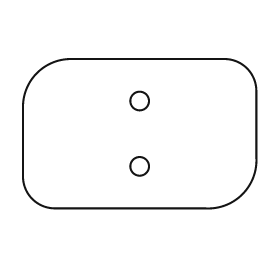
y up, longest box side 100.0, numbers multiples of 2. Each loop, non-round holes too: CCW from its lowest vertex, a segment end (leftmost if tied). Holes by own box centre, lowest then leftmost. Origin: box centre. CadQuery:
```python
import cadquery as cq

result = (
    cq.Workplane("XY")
    .moveTo(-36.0, -32.0)
    .lineTo(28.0, -32.0)
    .threePointArc((44.0, -26.0), (50.0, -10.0))
    .lineTo(50.0, 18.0)
    .threePointArc((46.0, 28.0), (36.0, 32.0))
    .lineTo(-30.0, 32.0)
    .threePointArc((-44.0, 26.0), (-50.0, 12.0))
    .lineTo(-50.0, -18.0)
    .threePointArc((-46.0, -28.0), (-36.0, -32.0))
    .close()
    .moveTo(0.0, -14.0)
    .circle(4.0)
    .moveTo(0.0, 14.0)
    .circle(4.0)
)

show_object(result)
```